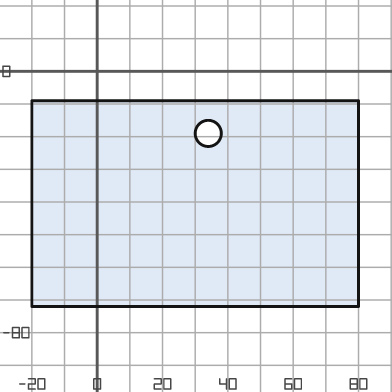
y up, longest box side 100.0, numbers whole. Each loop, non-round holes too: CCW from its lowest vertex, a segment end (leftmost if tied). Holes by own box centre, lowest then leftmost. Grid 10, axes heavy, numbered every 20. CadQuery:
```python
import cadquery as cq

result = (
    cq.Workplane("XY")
    .moveTo(-20.0, -72.0)
    .lineTo(80.0, -72.0)
    .lineTo(80.0, -9.0)
    .lineTo(-20.0, -9.0)
    .close()
    .moveTo(34.0, -19.0)
    .circle(4.0)
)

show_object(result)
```